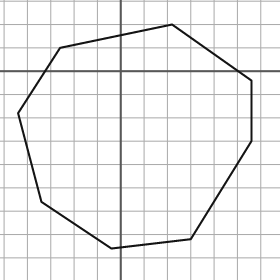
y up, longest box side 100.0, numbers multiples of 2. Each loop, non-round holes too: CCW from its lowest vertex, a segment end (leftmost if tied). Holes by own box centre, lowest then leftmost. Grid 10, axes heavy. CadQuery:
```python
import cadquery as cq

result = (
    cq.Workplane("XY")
    .moveTo(-4.0, -76.0)
    .lineTo(30.0, -72.0)
    .lineTo(56.0, -30.0)
    .lineTo(56.0, -4.0)
    .lineTo(22.0, 20.0)
    .lineTo(-26.0, 10.0)
    .lineTo(-44.0, -18.0)
    .lineTo(-34.0, -56.0)
    .close()
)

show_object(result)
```